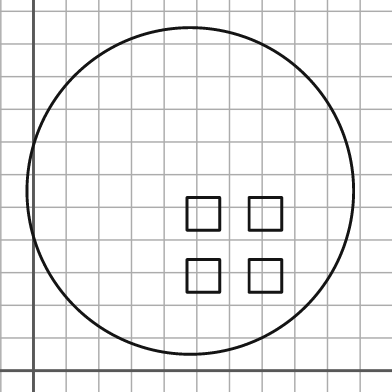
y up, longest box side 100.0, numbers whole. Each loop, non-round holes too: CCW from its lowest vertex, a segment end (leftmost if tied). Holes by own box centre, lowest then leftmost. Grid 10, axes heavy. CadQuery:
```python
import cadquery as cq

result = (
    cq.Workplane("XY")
    .moveTo(48.0, 55.0)
    .circle(50.0)
    .moveTo(47.0, 24.0)
    .lineTo(57.0, 24.0)
    .lineTo(57.0, 34.0)
    .lineTo(47.0, 34.0)
    .close()
    .moveTo(66.0, 24.0)
    .lineTo(76.0, 24.0)
    .lineTo(76.0, 34.0)
    .lineTo(66.0, 34.0)
    .close()
    .moveTo(47.0, 43.0)
    .lineTo(57.0, 43.0)
    .lineTo(57.0, 53.0)
    .lineTo(47.0, 53.0)
    .close()
    .moveTo(66.0, 43.0)
    .lineTo(76.0, 43.0)
    .lineTo(76.0, 53.0)
    .lineTo(66.0, 53.0)
    .close()
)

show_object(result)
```